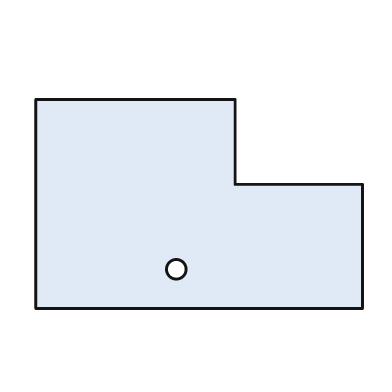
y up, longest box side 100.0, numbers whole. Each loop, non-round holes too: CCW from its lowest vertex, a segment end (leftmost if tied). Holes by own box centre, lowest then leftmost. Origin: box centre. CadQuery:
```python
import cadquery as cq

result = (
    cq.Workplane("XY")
    .moveTo(-50.0, -32.0)
    .lineTo(50.0, -32.0)
    .lineTo(50.0, 6.0)
    .lineTo(11.0, 6.0)
    .lineTo(11.0, 32.0)
    .lineTo(-50.0, 32.0)
    .close()
    .moveTo(-7.0, -20.0)
    .circle(3.0)
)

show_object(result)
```